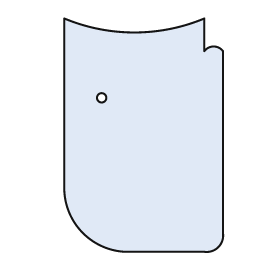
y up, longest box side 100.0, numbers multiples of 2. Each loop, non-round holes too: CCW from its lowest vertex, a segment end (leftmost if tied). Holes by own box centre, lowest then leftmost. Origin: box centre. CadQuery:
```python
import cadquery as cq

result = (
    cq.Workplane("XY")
    .moveTo(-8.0, -50.0)
    .lineTo(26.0, -50.0)
    .threePointArc((32.0, -48.0), (34.0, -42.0))
    .lineTo(34.0, 36.0)
    .threePointArc((30.0, 38.0), (26.0, 36.0))
    .lineTo(26.0, 50.0)
    .threePointArc((-4.0, 44.0), (-34.0, 50.0))
    .lineTo(-34.0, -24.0)
    .threePointArc((-26.0, -42.0), (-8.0, -50.0))
    .close()
    .moveTo(-18.0, 16.0)
    .circle(2.0)
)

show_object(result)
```